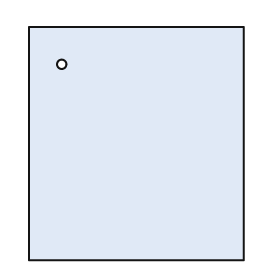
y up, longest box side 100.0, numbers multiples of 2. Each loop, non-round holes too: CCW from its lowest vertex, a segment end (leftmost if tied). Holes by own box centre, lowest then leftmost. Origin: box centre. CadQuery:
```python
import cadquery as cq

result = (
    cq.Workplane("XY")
    .moveTo(-46.0, -50.0)
    .lineTo(46.0, -50.0)
    .lineTo(46.0, 50.0)
    .lineTo(-46.0, 50.0)
    .close()
    .moveTo(-32.0, 34.0)
    .circle(2.0)
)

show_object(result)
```